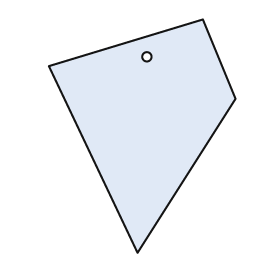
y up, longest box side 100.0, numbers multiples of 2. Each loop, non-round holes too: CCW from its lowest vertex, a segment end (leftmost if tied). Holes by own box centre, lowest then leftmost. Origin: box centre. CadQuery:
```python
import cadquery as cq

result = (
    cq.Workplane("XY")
    .moveTo(-2.0, -50.0)
    .lineTo(40.0, 16.0)
    .lineTo(26.0, 50.0)
    .lineTo(-40.0, 30.0)
    .close()
    .moveTo(2.0, 34.0)
    .circle(2.0)
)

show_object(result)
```